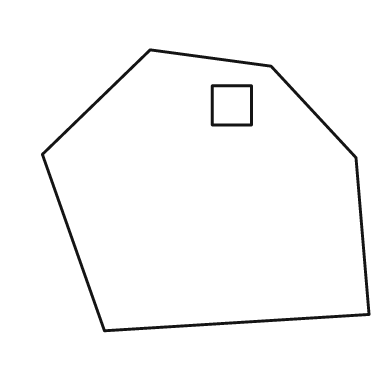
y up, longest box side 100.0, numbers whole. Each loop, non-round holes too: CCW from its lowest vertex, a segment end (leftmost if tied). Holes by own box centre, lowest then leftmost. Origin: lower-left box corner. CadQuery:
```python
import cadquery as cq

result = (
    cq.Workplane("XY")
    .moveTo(19.0, 0.0)
    .lineTo(100.0, 5.0)
    .lineTo(96.0, 53.0)
    .lineTo(70.0, 81.0)
    .lineTo(33.0, 86.0)
    .lineTo(0.0, 54.0)
    .close()
    .moveTo(52.0, 63.0)
    .lineTo(64.0, 63.0)
    .lineTo(64.0, 75.0)
    .lineTo(52.0, 75.0)
    .close()
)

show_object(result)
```